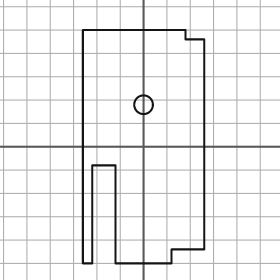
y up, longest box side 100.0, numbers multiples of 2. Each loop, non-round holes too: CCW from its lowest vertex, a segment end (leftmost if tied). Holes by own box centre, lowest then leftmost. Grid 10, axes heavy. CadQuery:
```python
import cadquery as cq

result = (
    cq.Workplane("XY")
    .moveTo(-26.0, -50.0)
    .lineTo(-22.0, -50.0)
    .lineTo(-22.0, -8.0)
    .lineTo(-12.0, -8.0)
    .lineTo(-12.0, -50.0)
    .lineTo(12.0, -50.0)
    .lineTo(12.0, -44.0)
    .lineTo(26.0, -44.0)
    .lineTo(26.0, 46.0)
    .lineTo(18.0, 46.0)
    .lineTo(18.0, 50.0)
    .lineTo(-26.0, 50.0)
    .close()
    .moveTo(0.0, 18.0)
    .circle(4.0)
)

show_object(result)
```